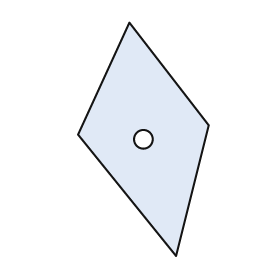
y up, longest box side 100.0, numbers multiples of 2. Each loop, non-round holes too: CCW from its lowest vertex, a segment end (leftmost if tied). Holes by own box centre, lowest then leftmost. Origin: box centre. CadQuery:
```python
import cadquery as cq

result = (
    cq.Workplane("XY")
    .moveTo(14.0, -50.0)
    .lineTo(28.0, 6.0)
    .lineTo(-6.0, 50.0)
    .lineTo(-28.0, 2.0)
    .close()
    .moveTo(0.0, 0.0)
    .circle(4.0)
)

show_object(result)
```